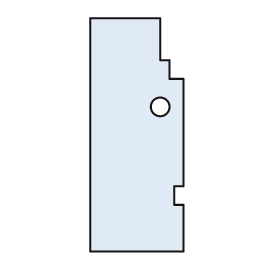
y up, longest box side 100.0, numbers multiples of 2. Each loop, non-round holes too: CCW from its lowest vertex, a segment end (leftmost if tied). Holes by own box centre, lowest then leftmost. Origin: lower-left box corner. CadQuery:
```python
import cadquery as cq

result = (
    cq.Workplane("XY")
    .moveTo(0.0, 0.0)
    .lineTo(40.0, 0.0)
    .lineTo(40.0, 20.0)
    .lineTo(36.0, 20.0)
    .lineTo(36.0, 28.0)
    .lineTo(40.0, 28.0)
    .lineTo(40.0, 74.0)
    .lineTo(34.0, 74.0)
    .lineTo(34.0, 82.0)
    .lineTo(30.0, 82.0)
    .lineTo(30.0, 100.0)
    .lineTo(0.0, 100.0)
    .close()
    .moveTo(30.0, 62.0)
    .circle(4.0)
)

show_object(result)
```